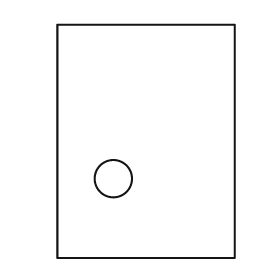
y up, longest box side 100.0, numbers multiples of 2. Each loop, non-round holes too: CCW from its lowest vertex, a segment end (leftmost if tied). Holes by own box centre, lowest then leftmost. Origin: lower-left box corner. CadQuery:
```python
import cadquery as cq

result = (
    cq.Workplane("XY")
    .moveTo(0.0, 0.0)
    .lineTo(76.0, 0.0)
    .lineTo(76.0, 100.0)
    .lineTo(0.0, 100.0)
    .close()
    .moveTo(24.0, 34.0)
    .circle(8.0)
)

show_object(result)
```